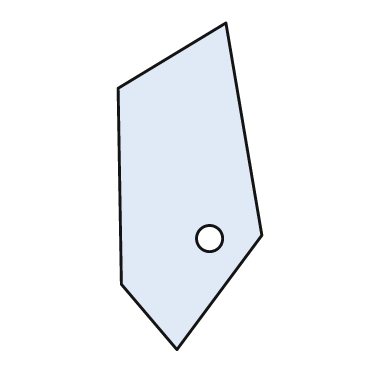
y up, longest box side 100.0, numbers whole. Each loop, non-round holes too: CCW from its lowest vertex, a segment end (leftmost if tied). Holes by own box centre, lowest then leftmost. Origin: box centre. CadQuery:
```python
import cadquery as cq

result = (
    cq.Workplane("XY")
    .moveTo(-4.0, -50.0)
    .lineTo(22.0, -15.0)
    .lineTo(11.0, 50.0)
    .lineTo(-22.0, 30.0)
    .lineTo(-21.0, -30.0)
    .close()
    .moveTo(6.0, -16.0)
    .circle(4.0)
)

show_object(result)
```